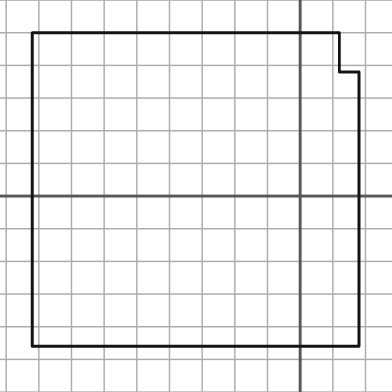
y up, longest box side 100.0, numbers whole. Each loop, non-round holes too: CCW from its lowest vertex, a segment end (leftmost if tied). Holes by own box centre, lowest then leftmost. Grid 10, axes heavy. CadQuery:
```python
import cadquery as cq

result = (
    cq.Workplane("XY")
    .moveTo(-82.0, -46.0)
    .lineTo(18.0, -46.0)
    .lineTo(18.0, 38.0)
    .lineTo(12.0, 38.0)
    .lineTo(12.0, 50.0)
    .lineTo(-82.0, 50.0)
    .close()
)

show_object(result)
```